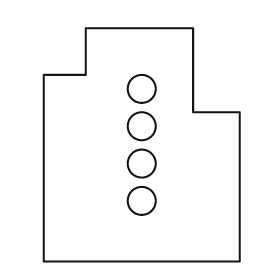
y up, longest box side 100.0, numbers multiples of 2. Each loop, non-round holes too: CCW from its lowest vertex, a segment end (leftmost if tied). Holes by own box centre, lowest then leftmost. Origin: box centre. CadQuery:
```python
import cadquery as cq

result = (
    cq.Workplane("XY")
    .moveTo(-42.0, -50.0)
    .lineTo(42.0, -50.0)
    .lineTo(42.0, 14.0)
    .lineTo(22.0, 14.0)
    .lineTo(22.0, 50.0)
    .lineTo(-24.0, 50.0)
    .lineTo(-24.0, 30.0)
    .lineTo(-42.0, 30.0)
    .close()
    .moveTo(0.0, -24.0)
    .circle(6.0)
    .moveTo(0.0, -8.0)
    .circle(6.0)
    .moveTo(0.0, 8.0)
    .circle(6.0)
    .moveTo(0.0, 24.0)
    .circle(6.0)
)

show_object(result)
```